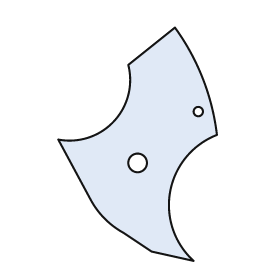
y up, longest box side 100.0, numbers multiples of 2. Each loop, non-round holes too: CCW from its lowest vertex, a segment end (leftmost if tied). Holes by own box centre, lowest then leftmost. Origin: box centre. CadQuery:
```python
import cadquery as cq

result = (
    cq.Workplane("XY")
    .moveTo(24.0, -50.0)
    .threePointArc((14.0, -20.0), (34.0, 4.0))
    .threePointArc((28.0, 28.0), (16.0, 50.0))
    .lineTo(-4.0, 34.0)
    .threePointArc((-10.0, 10.0), (-34.0, 2.0))
    .lineTo(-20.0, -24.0)
    .threePointArc((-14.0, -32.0), (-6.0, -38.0))
    .lineTo(6.0, -46.0)
    .close()
    .moveTo(0.0, -8.0)
    .circle(4.0)
    .moveTo(26.0, 14.0)
    .circle(2.0)
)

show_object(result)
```